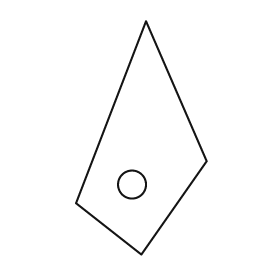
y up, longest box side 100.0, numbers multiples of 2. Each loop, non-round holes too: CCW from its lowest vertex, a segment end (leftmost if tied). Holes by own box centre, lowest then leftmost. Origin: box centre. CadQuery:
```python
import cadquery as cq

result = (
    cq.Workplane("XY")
    .moveTo(0.0, -50.0)
    .lineTo(28.0, -10.0)
    .lineTo(2.0, 50.0)
    .lineTo(-28.0, -28.0)
    .close()
    .moveTo(-4.0, -20.0)
    .circle(6.0)
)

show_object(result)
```